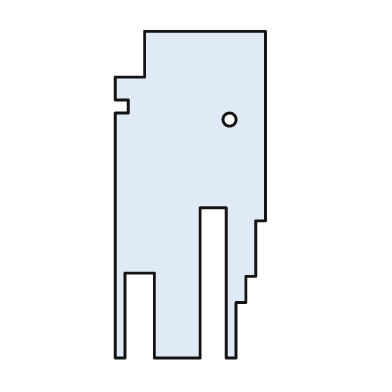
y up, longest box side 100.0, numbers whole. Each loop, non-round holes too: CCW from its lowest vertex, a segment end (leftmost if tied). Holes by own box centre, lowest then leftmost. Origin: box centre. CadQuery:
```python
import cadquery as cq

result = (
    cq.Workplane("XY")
    .moveTo(-23.0, -50.0)
    .lineTo(-20.0, -50.0)
    .lineTo(-20.0, -24.0)
    .lineTo(-11.0, -24.0)
    .lineTo(-11.0, -50.0)
    .lineTo(3.0, -50.0)
    .lineTo(3.0, -4.0)
    .lineTo(11.0, -4.0)
    .lineTo(11.0, -50.0)
    .lineTo(14.0, -50.0)
    .lineTo(14.0, -33.0)
    .lineTo(17.0, -33.0)
    .lineTo(17.0, -25.0)
    .lineTo(20.0, -25.0)
    .lineTo(20.0, -8.0)
    .lineTo(23.0, -8.0)
    .lineTo(23.0, 50.0)
    .lineTo(-14.0, 50.0)
    .lineTo(-14.0, 36.0)
    .lineTo(-23.0, 36.0)
    .lineTo(-23.0, 29.0)
    .lineTo(-19.0, 29.0)
    .lineTo(-19.0, 25.0)
    .lineTo(-23.0, 25.0)
    .close()
    .moveTo(12.0, 23.0)
    .circle(2.0)
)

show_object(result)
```